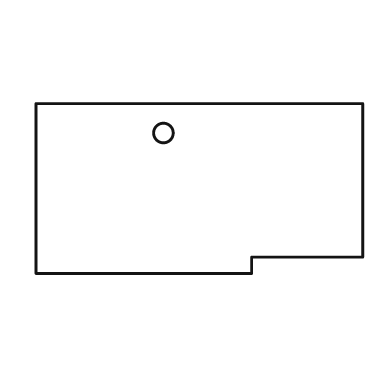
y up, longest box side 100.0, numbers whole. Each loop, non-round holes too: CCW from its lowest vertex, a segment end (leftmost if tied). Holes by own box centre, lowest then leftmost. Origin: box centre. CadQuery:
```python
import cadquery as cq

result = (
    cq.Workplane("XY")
    .moveTo(-50.0, -26.0)
    .lineTo(16.0, -26.0)
    .lineTo(16.0, -21.0)
    .lineTo(50.0, -21.0)
    .lineTo(50.0, 26.0)
    .lineTo(-50.0, 26.0)
    .close()
    .moveTo(-11.0, 17.0)
    .circle(3.0)
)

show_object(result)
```